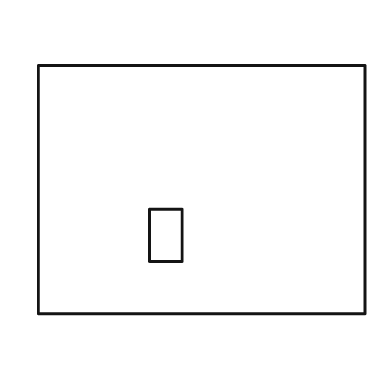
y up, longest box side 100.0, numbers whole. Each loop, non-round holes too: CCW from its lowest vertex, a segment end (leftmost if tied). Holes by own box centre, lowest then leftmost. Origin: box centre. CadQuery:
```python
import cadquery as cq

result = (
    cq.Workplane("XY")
    .moveTo(-50.0, -38.0)
    .lineTo(50.0, -38.0)
    .lineTo(50.0, 38.0)
    .lineTo(-50.0, 38.0)
    .close()
    .moveTo(-16.0, -22.0)
    .lineTo(-6.0, -22.0)
    .lineTo(-6.0, -6.0)
    .lineTo(-16.0, -6.0)
    .close()
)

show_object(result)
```